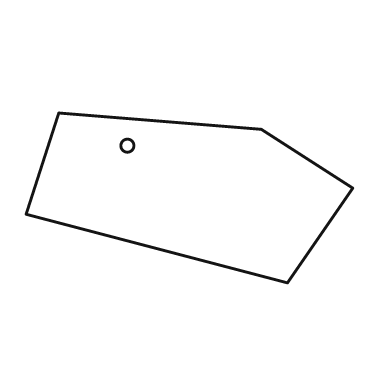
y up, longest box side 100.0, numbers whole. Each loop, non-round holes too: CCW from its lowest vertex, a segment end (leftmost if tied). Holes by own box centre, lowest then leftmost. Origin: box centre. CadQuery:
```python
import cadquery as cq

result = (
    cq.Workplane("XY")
    .moveTo(30.0, -26.0)
    .lineTo(50.0, 3.0)
    .lineTo(22.0, 21.0)
    .lineTo(-40.0, 26.0)
    .lineTo(-50.0, -5.0)
    .close()
    .moveTo(-19.0, 16.0)
    .circle(2.0)
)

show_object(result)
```